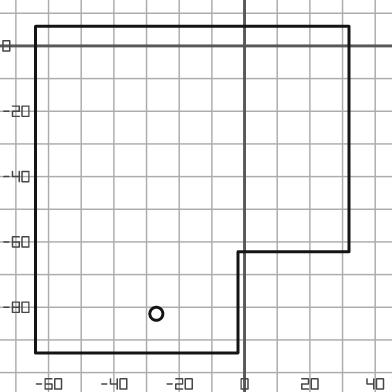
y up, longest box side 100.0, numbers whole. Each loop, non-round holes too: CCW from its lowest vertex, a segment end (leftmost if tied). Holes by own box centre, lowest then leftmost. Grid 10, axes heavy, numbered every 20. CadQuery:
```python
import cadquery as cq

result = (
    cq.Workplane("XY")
    .moveTo(-64.0, -94.0)
    .lineTo(-2.0, -94.0)
    .lineTo(-2.0, -63.0)
    .lineTo(32.0, -63.0)
    .lineTo(32.0, 6.0)
    .lineTo(-64.0, 6.0)
    .close()
    .moveTo(-27.0, -82.0)
    .circle(2.0)
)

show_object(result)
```